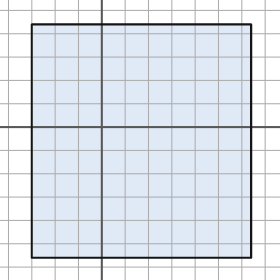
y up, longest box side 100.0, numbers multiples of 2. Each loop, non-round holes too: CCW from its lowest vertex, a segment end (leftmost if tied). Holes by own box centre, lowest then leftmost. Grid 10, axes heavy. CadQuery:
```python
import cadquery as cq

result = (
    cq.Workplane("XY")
    .moveTo(-30.0, -56.0)
    .lineTo(64.0, -56.0)
    .lineTo(64.0, 44.0)
    .lineTo(-30.0, 44.0)
    .close()
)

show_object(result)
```